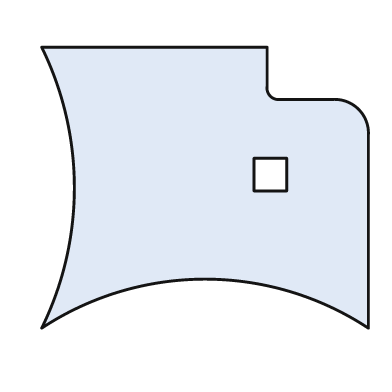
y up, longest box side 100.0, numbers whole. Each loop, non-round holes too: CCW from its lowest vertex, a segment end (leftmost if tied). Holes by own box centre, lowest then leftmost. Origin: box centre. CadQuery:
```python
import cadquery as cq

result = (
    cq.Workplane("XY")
    .moveTo(-50.0, -43.0)
    .threePointArc((0.0, -28.0), (50.0, -43.0))
    .lineTo(50.0, 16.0)
    .threePointArc((47.0, 24.0), (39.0, 27.0))
    .lineTo(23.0, 27.0)
    .threePointArc((20.0, 28.0), (19.0, 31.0))
    .lineTo(19.0, 43.0)
    .lineTo(-50.0, 43.0)
    .threePointArc((-40.0, 0.0), (-50.0, -43.0))
    .close()
    .moveTo(15.0, -1.0)
    .lineTo(25.0, -1.0)
    .lineTo(25.0, 9.0)
    .lineTo(15.0, 9.0)
    .close()
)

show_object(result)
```